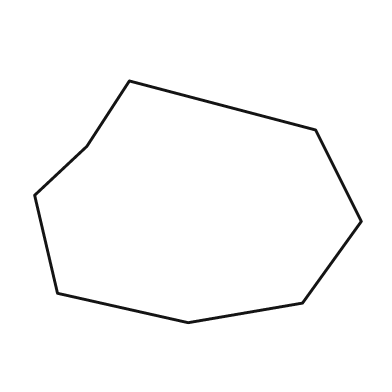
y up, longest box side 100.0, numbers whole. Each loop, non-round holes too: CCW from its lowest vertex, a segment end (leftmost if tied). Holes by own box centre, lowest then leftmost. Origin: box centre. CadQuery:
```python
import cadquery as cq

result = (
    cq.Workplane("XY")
    .moveTo(-3.0, -37.0)
    .lineTo(32.0, -31.0)
    .lineTo(50.0, -6.0)
    .lineTo(36.0, 22.0)
    .lineTo(-21.0, 37.0)
    .lineTo(-34.0, 17.0)
    .lineTo(-50.0, 2.0)
    .lineTo(-43.0, -28.0)
    .close()
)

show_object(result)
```